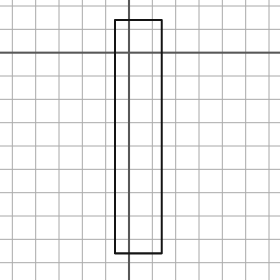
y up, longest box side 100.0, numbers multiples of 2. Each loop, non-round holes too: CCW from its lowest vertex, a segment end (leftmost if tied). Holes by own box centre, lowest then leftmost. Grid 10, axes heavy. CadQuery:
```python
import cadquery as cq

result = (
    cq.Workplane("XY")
    .moveTo(-6.0, -86.0)
    .lineTo(14.0, -86.0)
    .lineTo(14.0, 14.0)
    .lineTo(-6.0, 14.0)
    .close()
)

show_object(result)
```